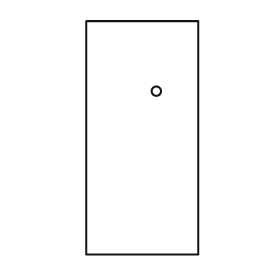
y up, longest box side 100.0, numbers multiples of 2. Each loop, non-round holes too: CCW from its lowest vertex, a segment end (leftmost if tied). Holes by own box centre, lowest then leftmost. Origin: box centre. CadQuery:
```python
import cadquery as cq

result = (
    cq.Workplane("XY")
    .moveTo(-24.0, -50.0)
    .lineTo(24.0, -50.0)
    .lineTo(24.0, 50.0)
    .lineTo(-24.0, 50.0)
    .close()
    .moveTo(6.0, 20.0)
    .circle(2.0)
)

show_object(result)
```